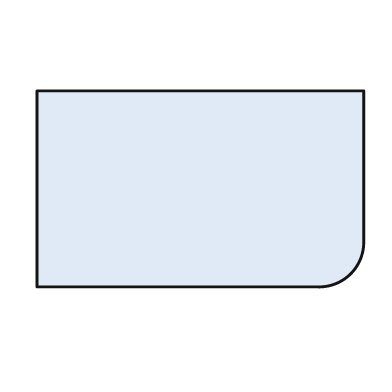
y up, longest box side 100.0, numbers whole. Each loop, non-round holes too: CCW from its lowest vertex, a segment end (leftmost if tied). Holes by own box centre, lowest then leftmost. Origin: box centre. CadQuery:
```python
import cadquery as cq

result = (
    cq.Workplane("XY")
    .moveTo(-50.0, -30.0)
    .lineTo(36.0, -30.0)
    .threePointArc((46.0, -26.0), (50.0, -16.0))
    .lineTo(50.0, 30.0)
    .lineTo(-50.0, 30.0)
    .close()
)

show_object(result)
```